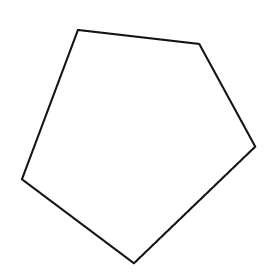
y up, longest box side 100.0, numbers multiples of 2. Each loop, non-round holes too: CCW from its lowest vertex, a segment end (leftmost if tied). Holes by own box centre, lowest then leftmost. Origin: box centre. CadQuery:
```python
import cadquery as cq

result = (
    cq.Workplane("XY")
    .moveTo(-2.0, -50.0)
    .lineTo(50.0, 0.0)
    .lineTo(26.0, 44.0)
    .lineTo(-26.0, 50.0)
    .lineTo(-50.0, -14.0)
    .close()
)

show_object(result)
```